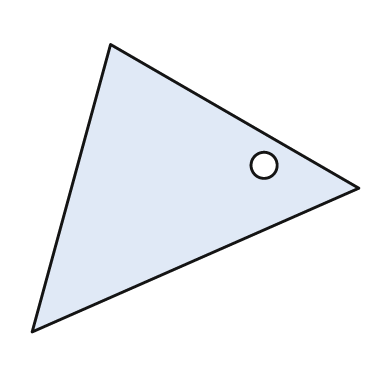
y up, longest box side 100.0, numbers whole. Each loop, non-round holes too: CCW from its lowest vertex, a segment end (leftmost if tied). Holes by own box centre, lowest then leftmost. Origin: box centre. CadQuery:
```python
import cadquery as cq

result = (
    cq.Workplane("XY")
    .moveTo(-50.0, -44.0)
    .lineTo(50.0, 0.0)
    .lineTo(-26.0, 44.0)
    .close()
    .moveTo(21.0, 7.0)
    .circle(4.0)
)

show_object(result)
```